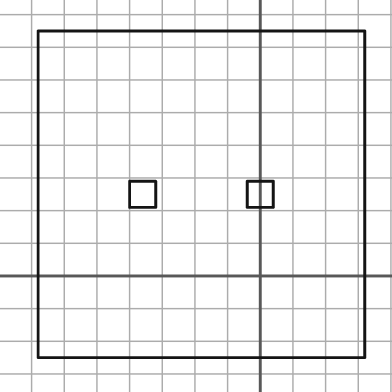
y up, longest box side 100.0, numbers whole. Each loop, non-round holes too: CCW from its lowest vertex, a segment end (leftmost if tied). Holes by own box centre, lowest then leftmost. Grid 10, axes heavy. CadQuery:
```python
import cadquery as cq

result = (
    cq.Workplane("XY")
    .moveTo(-68.0, -25.0)
    .lineTo(32.0, -25.0)
    .lineTo(32.0, 75.0)
    .lineTo(-68.0, 75.0)
    .close()
    .moveTo(-40.0, 21.0)
    .lineTo(-32.0, 21.0)
    .lineTo(-32.0, 29.0)
    .lineTo(-40.0, 29.0)
    .close()
    .moveTo(-4.0, 21.0)
    .lineTo(4.0, 21.0)
    .lineTo(4.0, 29.0)
    .lineTo(-4.0, 29.0)
    .close()
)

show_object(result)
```